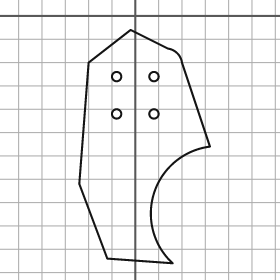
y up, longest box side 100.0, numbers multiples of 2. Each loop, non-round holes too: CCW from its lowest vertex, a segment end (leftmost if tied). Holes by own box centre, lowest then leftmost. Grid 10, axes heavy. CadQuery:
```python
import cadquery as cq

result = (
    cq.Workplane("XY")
    .moveTo(16.0, -106.0)
    .threePointArc((8.0, -76.0), (32.0, -56.0))
    .lineTo(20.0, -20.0)
    .threePointArc((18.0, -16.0), (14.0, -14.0))
    .lineTo(-2.0, -6.0)
    .lineTo(-20.0, -20.0)
    .lineTo(-24.0, -72.0)
    .lineTo(-12.0, -104.0)
    .close()
    .moveTo(-8.0, -42.0)
    .circle(2.0)
    .moveTo(8.0, -42.0)
    .circle(2.0)
    .moveTo(-8.0, -26.0)
    .circle(2.0)
    .moveTo(8.0, -26.0)
    .circle(2.0)
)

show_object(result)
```